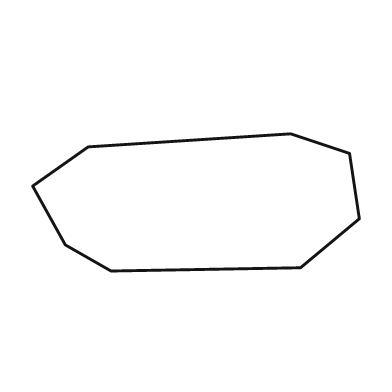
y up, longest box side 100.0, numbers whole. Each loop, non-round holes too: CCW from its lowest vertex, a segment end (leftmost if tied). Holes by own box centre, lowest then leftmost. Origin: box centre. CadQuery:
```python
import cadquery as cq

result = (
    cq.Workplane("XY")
    .moveTo(-26.0, -21.0)
    .lineTo(32.0, -20.0)
    .lineTo(50.0, -5.0)
    .lineTo(47.0, 15.0)
    .lineTo(29.0, 21.0)
    .lineTo(-33.0, 17.0)
    .lineTo(-50.0, 5.0)
    .lineTo(-40.0, -13.0)
    .close()
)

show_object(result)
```